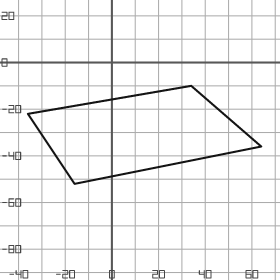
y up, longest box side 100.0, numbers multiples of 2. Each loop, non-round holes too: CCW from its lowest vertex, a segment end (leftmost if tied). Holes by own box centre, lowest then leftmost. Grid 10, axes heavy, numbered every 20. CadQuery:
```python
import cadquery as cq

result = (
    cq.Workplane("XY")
    .moveTo(-16.0, -52.0)
    .lineTo(64.0, -36.0)
    .lineTo(34.0, -10.0)
    .lineTo(-36.0, -22.0)
    .close()
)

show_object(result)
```